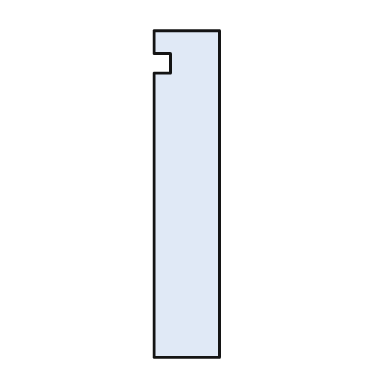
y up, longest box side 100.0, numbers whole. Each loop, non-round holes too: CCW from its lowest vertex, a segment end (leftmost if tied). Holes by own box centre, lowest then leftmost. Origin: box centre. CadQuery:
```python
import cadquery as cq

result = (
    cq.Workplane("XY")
    .moveTo(-10.0, -50.0)
    .lineTo(10.0, -50.0)
    .lineTo(10.0, 50.0)
    .lineTo(-10.0, 50.0)
    .lineTo(-10.0, 43.0)
    .lineTo(-5.0, 43.0)
    .lineTo(-5.0, 37.0)
    .lineTo(-10.0, 37.0)
    .close()
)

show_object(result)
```